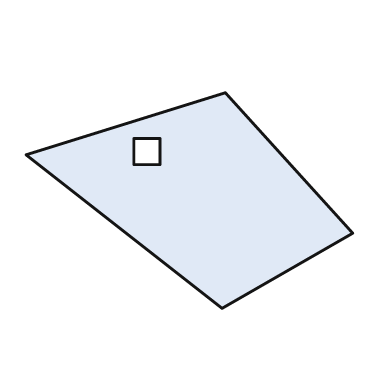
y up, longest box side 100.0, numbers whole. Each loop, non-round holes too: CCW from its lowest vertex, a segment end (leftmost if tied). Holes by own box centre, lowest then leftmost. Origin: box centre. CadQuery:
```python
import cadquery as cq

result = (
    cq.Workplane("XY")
    .moveTo(10.0, -33.0)
    .lineTo(50.0, -10.0)
    .lineTo(11.0, 33.0)
    .lineTo(-50.0, 14.0)
    .close()
    .moveTo(-17.0, 11.0)
    .lineTo(-9.0, 11.0)
    .lineTo(-9.0, 19.0)
    .lineTo(-17.0, 19.0)
    .close()
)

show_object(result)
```